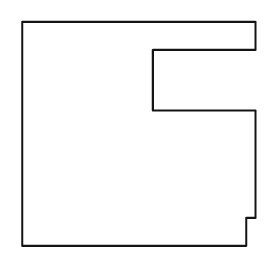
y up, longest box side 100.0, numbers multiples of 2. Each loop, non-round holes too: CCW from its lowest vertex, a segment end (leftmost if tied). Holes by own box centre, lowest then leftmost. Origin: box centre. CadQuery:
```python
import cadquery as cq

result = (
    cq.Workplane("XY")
    .moveTo(-50.0, -48.0)
    .lineTo(46.0, -48.0)
    .lineTo(46.0, -36.0)
    .lineTo(50.0, -36.0)
    .lineTo(50.0, 10.0)
    .lineTo(6.0, 10.0)
    .lineTo(6.0, 36.0)
    .lineTo(50.0, 36.0)
    .lineTo(50.0, 48.0)
    .lineTo(-50.0, 48.0)
    .close()
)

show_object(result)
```